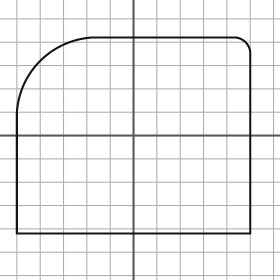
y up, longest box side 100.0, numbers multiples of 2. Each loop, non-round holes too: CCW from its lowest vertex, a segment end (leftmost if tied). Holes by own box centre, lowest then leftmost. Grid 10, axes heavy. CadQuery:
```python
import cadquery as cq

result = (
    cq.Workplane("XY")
    .moveTo(-50.0, -42.0)
    .lineTo(50.0, -42.0)
    .lineTo(50.0, 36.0)
    .threePointArc((48.0, 40.0), (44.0, 42.0))
    .lineTo(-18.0, 42.0)
    .threePointArc((-40.0, 32.0), (-50.0, 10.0))
    .close()
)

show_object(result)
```